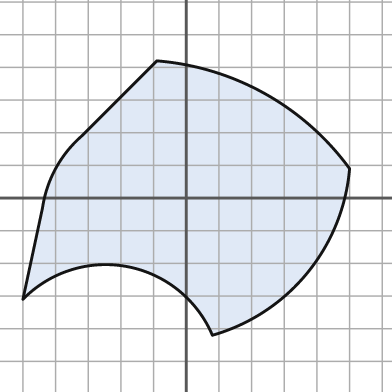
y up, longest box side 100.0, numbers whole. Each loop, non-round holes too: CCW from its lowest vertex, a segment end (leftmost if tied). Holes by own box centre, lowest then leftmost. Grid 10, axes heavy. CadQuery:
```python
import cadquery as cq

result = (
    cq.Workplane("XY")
    .moveTo(8.0, -42.0)
    .threePointArc((37.0, -23.0), (50.0, 9.0))
    .threePointArc((24.0, 32.0), (-9.0, 42.0))
    .lineTo(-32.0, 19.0)
    .threePointArc((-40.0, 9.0), (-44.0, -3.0))
    .lineTo(-50.0, -31.0)
    .threePointArc((-18.0, -21.0), (8.0, -42.0))
    .close()
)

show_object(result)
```